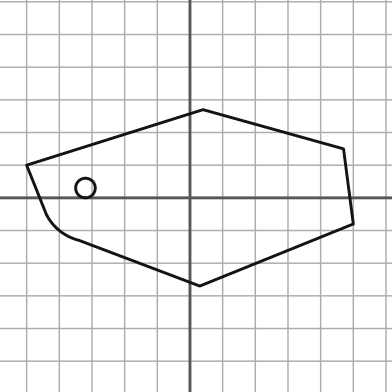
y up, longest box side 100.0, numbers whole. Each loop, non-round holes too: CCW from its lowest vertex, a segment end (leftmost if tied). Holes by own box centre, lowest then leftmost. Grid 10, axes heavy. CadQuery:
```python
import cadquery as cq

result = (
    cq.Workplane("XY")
    .moveTo(3.0, -27.0)
    .lineTo(50.0, -8.0)
    .lineTo(47.0, 15.0)
    .lineTo(4.0, 27.0)
    .lineTo(-50.0, 10.0)
    .lineTo(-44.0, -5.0)
    .threePointArc((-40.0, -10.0), (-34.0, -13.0))
    .close()
    .moveTo(-32.0, 3.0)
    .circle(3.0)
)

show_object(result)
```